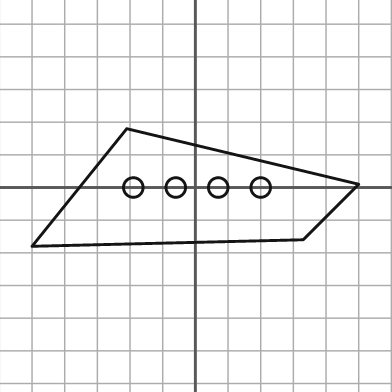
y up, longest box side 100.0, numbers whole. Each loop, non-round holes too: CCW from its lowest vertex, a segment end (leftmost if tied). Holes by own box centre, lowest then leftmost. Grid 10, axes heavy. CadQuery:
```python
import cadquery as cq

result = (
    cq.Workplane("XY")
    .moveTo(-50.0, -18.0)
    .lineTo(33.0, -16.0)
    .lineTo(50.0, 1.0)
    .lineTo(-21.0, 18.0)
    .close()
    .moveTo(-19.0, 0.0)
    .circle(3.0)
    .moveTo(-6.0, 0.0)
    .circle(3.0)
    .moveTo(7.0, 0.0)
    .circle(3.0)
    .moveTo(20.0, 0.0)
    .circle(3.0)
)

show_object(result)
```